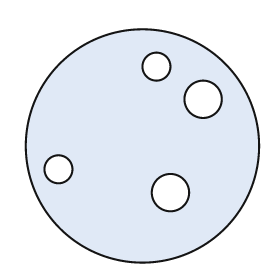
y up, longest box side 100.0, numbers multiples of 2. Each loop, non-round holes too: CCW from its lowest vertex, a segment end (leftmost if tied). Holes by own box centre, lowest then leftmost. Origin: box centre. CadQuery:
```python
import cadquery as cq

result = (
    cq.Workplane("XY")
    .moveTo(0.0, 0.0)
    .circle(50.0)
    .moveTo(12.0, -20.0)
    .circle(8.0)
    .moveTo(-36.0, -10.0)
    .circle(6.0)
    .moveTo(26.0, 20.0)
    .circle(8.0)
    .moveTo(6.0, 34.0)
    .circle(6.0)
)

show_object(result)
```